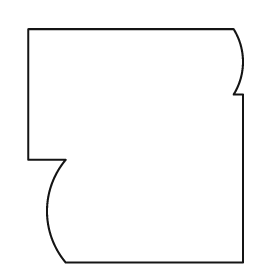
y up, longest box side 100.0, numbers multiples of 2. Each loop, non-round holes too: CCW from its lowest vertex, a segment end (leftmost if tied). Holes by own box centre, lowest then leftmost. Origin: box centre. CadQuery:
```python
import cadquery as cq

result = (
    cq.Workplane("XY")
    .moveTo(-30.0, -50.0)
    .lineTo(46.0, -50.0)
    .lineTo(46.0, 22.0)
    .lineTo(42.0, 22.0)
    .threePointArc((46.0, 36.0), (42.0, 50.0))
    .lineTo(-46.0, 50.0)
    .lineTo(-46.0, -6.0)
    .lineTo(-30.0, -6.0)
    .threePointArc((-38.0, -28.0), (-30.0, -50.0))
    .close()
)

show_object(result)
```